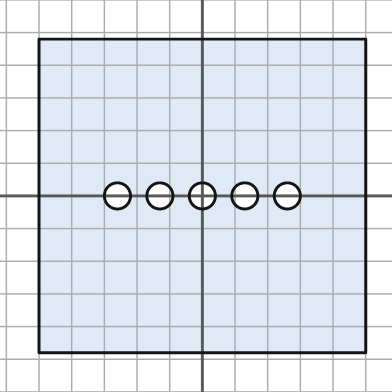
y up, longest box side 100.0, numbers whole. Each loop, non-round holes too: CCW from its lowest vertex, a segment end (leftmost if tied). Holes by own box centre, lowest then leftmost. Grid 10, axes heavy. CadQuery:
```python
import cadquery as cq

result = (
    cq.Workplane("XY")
    .moveTo(-50.0, -48.0)
    .lineTo(50.0, -48.0)
    .lineTo(50.0, 48.0)
    .lineTo(-50.0, 48.0)
    .close()
    .moveTo(-26.0, 0.0)
    .circle(4.0)
    .moveTo(-13.0, 0.0)
    .circle(4.0)
    .moveTo(0.0, 0.0)
    .circle(4.0)
    .moveTo(13.0, 0.0)
    .circle(4.0)
    .moveTo(26.0, 0.0)
    .circle(4.0)
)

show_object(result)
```